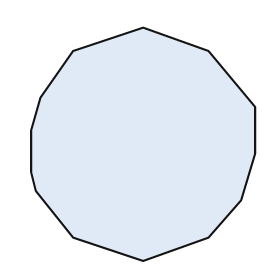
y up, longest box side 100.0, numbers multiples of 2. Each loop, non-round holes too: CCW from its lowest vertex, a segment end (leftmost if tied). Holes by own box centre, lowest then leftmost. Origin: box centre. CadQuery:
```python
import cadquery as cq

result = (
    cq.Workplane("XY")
    .moveTo(0.0, -50.0)
    .lineTo(28.0, -40.0)
    .lineTo(42.0, -24.0)
    .lineTo(48.0, -4.0)
    .lineTo(48.0, 16.0)
    .lineTo(28.0, 40.0)
    .lineTo(0.0, 50.0)
    .lineTo(-30.0, 40.0)
    .lineTo(-44.0, 20.0)
    .lineTo(-48.0, 6.0)
    .lineTo(-48.0, -12.0)
    .lineTo(-46.0, -20.0)
    .lineTo(-30.0, -40.0)
    .close()
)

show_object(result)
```